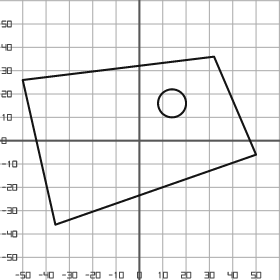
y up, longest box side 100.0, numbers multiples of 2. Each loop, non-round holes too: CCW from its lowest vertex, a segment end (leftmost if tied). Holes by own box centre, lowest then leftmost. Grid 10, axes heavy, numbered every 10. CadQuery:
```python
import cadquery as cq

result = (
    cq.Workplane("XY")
    .moveTo(-36.0, -36.0)
    .lineTo(50.0, -6.0)
    .lineTo(32.0, 36.0)
    .lineTo(-50.0, 26.0)
    .close()
    .moveTo(14.0, 16.0)
    .circle(6.0)
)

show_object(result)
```